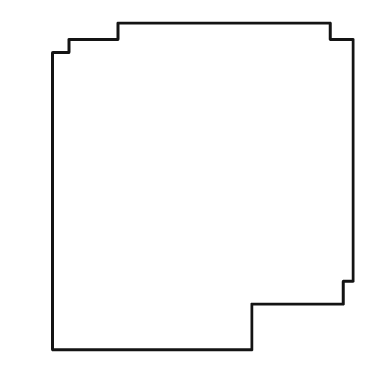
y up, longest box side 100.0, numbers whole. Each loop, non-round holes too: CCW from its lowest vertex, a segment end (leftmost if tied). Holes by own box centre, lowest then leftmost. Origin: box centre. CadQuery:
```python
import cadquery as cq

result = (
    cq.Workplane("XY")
    .moveTo(-46.0, -50.0)
    .lineTo(15.0, -50.0)
    .lineTo(15.0, -36.0)
    .lineTo(43.0, -36.0)
    .lineTo(43.0, -29.0)
    .lineTo(46.0, -29.0)
    .lineTo(46.0, 45.0)
    .lineTo(39.0, 45.0)
    .lineTo(39.0, 50.0)
    .lineTo(-26.0, 50.0)
    .lineTo(-26.0, 45.0)
    .lineTo(-41.0, 45.0)
    .lineTo(-41.0, 41.0)
    .lineTo(-46.0, 41.0)
    .close()
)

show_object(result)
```